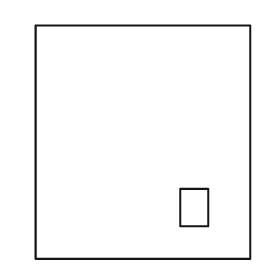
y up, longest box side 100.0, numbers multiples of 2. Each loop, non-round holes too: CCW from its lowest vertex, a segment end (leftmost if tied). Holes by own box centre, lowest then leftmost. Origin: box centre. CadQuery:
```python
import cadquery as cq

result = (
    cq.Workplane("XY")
    .moveTo(-46.0, -50.0)
    .lineTo(46.0, -50.0)
    .lineTo(46.0, 50.0)
    .lineTo(-46.0, 50.0)
    .close()
    .moveTo(16.0, -36.0)
    .lineTo(28.0, -36.0)
    .lineTo(28.0, -20.0)
    .lineTo(16.0, -20.0)
    .close()
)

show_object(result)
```